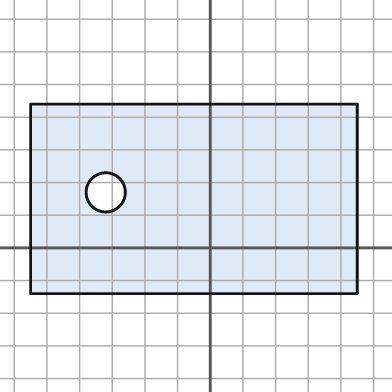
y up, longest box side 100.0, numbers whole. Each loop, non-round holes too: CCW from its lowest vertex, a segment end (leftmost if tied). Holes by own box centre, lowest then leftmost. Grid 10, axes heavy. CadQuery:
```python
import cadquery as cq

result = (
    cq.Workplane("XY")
    .moveTo(-55.0, -14.0)
    .lineTo(45.0, -14.0)
    .lineTo(45.0, 44.0)
    .lineTo(-55.0, 44.0)
    .close()
    .moveTo(-32.0, 17.0)
    .circle(6.0)
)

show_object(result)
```